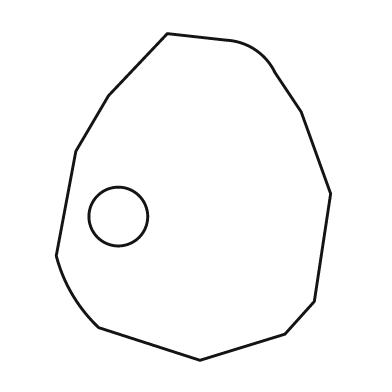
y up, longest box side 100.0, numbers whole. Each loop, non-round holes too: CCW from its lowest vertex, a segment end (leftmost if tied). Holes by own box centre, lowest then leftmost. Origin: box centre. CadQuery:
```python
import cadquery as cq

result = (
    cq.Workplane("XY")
    .moveTo(2.0, -50.0)
    .lineTo(28.0, -42.0)
    .lineTo(37.0, -32.0)
    .lineTo(42.0, 1.0)
    .lineTo(33.0, 26.0)
    .lineTo(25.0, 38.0)
    .threePointArc((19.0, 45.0), (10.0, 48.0))
    .lineTo(-8.0, 50.0)
    .lineTo(-26.0, 31.0)
    .lineTo(-36.0, 14.0)
    .lineTo(-42.0, -18.0)
    .threePointArc((-37.0, -30.0), (-29.0, -40.0))
    .close()
    .moveTo(-23.0, -6.0)
    .circle(9.0)
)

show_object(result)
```